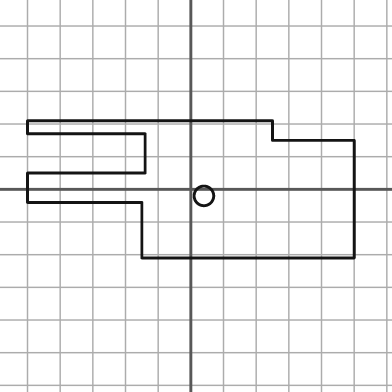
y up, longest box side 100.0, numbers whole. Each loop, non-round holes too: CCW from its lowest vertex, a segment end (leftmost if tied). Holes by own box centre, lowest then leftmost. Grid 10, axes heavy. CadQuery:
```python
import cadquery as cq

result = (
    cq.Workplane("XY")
    .moveTo(-15.0, -21.0)
    .lineTo(50.0, -21.0)
    .lineTo(50.0, 15.0)
    .lineTo(25.0, 15.0)
    .lineTo(25.0, 21.0)
    .lineTo(-50.0, 21.0)
    .lineTo(-50.0, 17.0)
    .lineTo(-14.0, 17.0)
    .lineTo(-14.0, 5.0)
    .lineTo(-50.0, 5.0)
    .lineTo(-50.0, -4.0)
    .lineTo(-15.0, -4.0)
    .close()
    .moveTo(4.0, -2.0)
    .circle(3.0)
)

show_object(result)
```